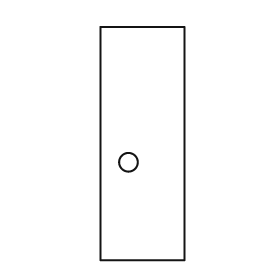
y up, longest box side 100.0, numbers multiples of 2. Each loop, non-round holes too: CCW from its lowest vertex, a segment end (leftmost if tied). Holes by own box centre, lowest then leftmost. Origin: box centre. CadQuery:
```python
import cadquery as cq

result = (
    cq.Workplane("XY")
    .moveTo(-18.0, -50.0)
    .lineTo(18.0, -50.0)
    .lineTo(18.0, 50.0)
    .lineTo(-18.0, 50.0)
    .close()
    .moveTo(-6.0, -8.0)
    .circle(4.0)
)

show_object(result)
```